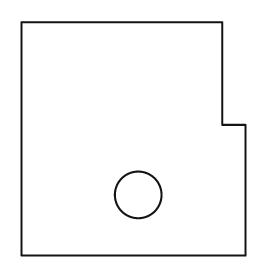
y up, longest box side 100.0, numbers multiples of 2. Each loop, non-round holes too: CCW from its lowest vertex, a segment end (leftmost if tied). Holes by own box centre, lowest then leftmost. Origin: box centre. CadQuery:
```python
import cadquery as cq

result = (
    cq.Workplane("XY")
    .moveTo(-48.0, -50.0)
    .lineTo(48.0, -50.0)
    .lineTo(48.0, 6.0)
    .lineTo(38.0, 6.0)
    .lineTo(38.0, 50.0)
    .lineTo(-48.0, 50.0)
    .close()
    .moveTo(2.0, -24.0)
    .circle(10.0)
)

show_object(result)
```